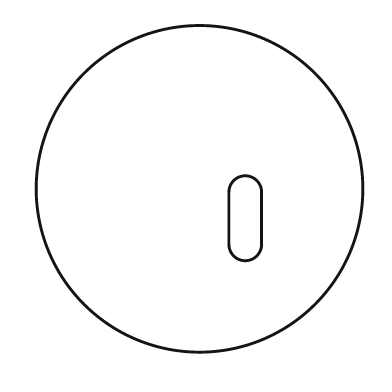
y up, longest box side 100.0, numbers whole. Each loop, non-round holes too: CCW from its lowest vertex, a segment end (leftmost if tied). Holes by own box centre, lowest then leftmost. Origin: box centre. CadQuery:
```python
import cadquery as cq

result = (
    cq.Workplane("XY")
    .moveTo(0.0, 0.0)
    .circle(50.0)
    .moveTo(9.0, -17.0)
    .threePointArc((14.0, -22.0), (19.0, -17.0))
    .lineTo(19.0, -1.0)
    .threePointArc((14.0, 4.0), (9.0, -1.0))
    .close()
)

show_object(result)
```